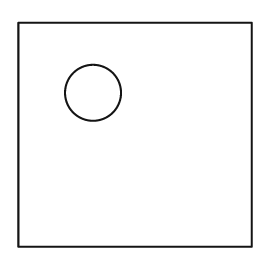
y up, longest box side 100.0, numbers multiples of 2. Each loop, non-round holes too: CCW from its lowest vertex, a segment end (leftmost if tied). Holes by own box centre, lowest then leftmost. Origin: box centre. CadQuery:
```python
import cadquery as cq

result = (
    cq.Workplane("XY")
    .moveTo(-50.0, -48.0)
    .lineTo(50.0, -48.0)
    .lineTo(50.0, 48.0)
    .lineTo(-50.0, 48.0)
    .close()
    .moveTo(-18.0, 18.0)
    .circle(12.0)
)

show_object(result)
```